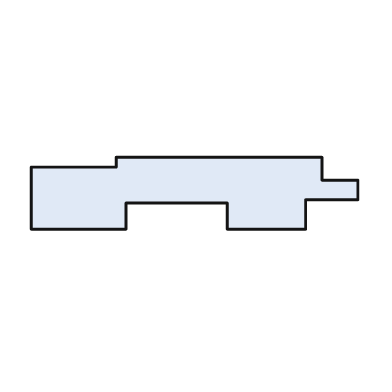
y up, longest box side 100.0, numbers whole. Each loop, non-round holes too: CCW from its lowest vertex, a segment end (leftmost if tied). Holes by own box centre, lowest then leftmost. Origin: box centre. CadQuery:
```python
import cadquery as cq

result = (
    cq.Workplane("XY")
    .moveTo(-50.0, -11.0)
    .lineTo(-21.0, -11.0)
    .lineTo(-21.0, -3.0)
    .lineTo(10.0, -3.0)
    .lineTo(10.0, -11.0)
    .lineTo(34.0, -11.0)
    .lineTo(34.0, -2.0)
    .lineTo(50.0, -2.0)
    .lineTo(50.0, 4.0)
    .lineTo(39.0, 4.0)
    .lineTo(39.0, 11.0)
    .lineTo(-24.0, 11.0)
    .lineTo(-24.0, 8.0)
    .lineTo(-50.0, 8.0)
    .close()
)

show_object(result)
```